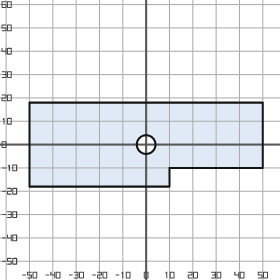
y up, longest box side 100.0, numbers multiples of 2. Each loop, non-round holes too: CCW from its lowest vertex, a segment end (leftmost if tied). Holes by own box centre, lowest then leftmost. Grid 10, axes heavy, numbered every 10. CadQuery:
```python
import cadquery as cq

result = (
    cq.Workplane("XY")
    .moveTo(-50.0, -18.0)
    .lineTo(10.0, -18.0)
    .lineTo(10.0, -10.0)
    .lineTo(50.0, -10.0)
    .lineTo(50.0, 18.0)
    .lineTo(-50.0, 18.0)
    .close()
    .moveTo(0.0, 0.0)
    .circle(4.0)
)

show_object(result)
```